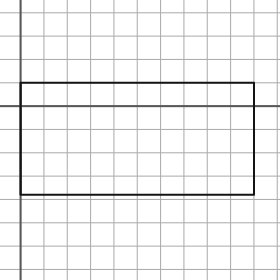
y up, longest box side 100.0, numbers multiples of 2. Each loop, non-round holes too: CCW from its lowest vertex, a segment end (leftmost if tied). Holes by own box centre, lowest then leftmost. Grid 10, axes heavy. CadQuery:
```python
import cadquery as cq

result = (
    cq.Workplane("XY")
    .moveTo(0.0, -38.0)
    .lineTo(100.0, -38.0)
    .lineTo(100.0, 10.0)
    .lineTo(0.0, 10.0)
    .close()
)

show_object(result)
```